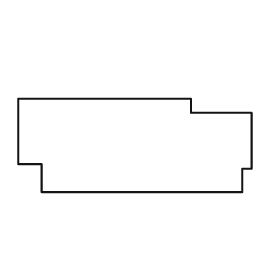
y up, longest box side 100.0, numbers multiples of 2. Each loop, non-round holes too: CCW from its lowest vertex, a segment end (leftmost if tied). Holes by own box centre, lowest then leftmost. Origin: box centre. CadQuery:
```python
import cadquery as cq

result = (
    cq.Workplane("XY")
    .moveTo(-40.0, -20.0)
    .lineTo(46.0, -20.0)
    .lineTo(46.0, -10.0)
    .lineTo(50.0, -10.0)
    .lineTo(50.0, 14.0)
    .lineTo(24.0, 14.0)
    .lineTo(24.0, 20.0)
    .lineTo(-50.0, 20.0)
    .lineTo(-50.0, -8.0)
    .lineTo(-40.0, -8.0)
    .close()
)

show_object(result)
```